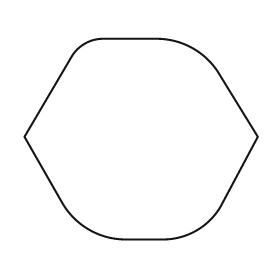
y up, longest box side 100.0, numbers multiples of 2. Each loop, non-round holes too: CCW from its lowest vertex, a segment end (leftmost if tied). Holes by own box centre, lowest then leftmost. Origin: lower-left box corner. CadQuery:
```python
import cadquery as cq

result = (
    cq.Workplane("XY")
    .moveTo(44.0, 0.0)
    .lineTo(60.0, 0.0)
    .threePointArc((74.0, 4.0), (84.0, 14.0))
    .lineTo(100.0, 44.0)
    .lineTo(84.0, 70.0)
    .threePointArc((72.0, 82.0), (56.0, 86.0))
    .lineTo(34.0, 86.0)
    .threePointArc((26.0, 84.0), (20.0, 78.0))
    .lineTo(0.0, 44.0)
    .lineTo(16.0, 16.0)
    .threePointArc((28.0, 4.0), (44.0, 0.0))
    .close()
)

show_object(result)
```